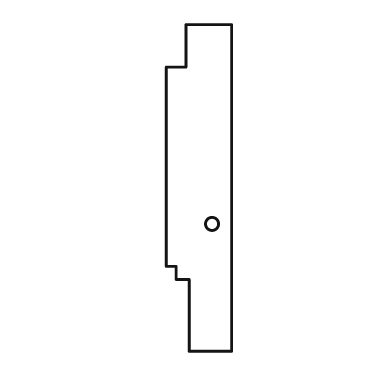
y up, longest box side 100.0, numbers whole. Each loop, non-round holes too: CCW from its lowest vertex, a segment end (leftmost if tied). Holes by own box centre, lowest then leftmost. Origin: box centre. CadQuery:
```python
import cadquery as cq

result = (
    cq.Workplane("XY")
    .moveTo(-3.0, -50.0)
    .lineTo(10.0, -50.0)
    .lineTo(10.0, 50.0)
    .lineTo(-4.0, 50.0)
    .lineTo(-4.0, 37.0)
    .lineTo(-10.0, 37.0)
    .lineTo(-10.0, -24.0)
    .lineTo(-7.0, -24.0)
    .lineTo(-7.0, -28.0)
    .lineTo(-3.0, -28.0)
    .close()
    .moveTo(4.0, -11.0)
    .circle(2.0)
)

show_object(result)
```